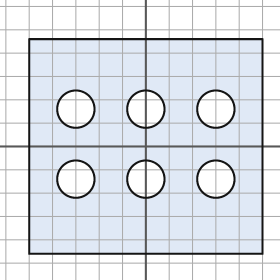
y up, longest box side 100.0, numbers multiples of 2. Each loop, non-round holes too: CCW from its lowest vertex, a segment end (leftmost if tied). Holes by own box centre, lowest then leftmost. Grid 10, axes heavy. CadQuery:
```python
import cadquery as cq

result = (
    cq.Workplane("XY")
    .moveTo(-50.0, -46.0)
    .lineTo(50.0, -46.0)
    .lineTo(50.0, 46.0)
    .lineTo(-50.0, 46.0)
    .close()
    .moveTo(-30.0, -14.0)
    .circle(8.0)
    .moveTo(0.0, -14.0)
    .circle(8.0)
    .moveTo(30.0, -14.0)
    .circle(8.0)
    .moveTo(-30.0, 16.0)
    .circle(8.0)
    .moveTo(0.0, 16.0)
    .circle(8.0)
    .moveTo(30.0, 16.0)
    .circle(8.0)
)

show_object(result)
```